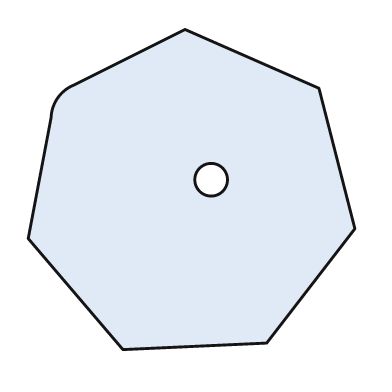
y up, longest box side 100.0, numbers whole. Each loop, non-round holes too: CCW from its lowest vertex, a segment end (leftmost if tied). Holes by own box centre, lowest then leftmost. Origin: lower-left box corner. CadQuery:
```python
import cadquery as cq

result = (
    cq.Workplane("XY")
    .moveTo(29.0, 0.0)
    .lineTo(73.0, 2.0)
    .lineTo(100.0, 37.0)
    .lineTo(89.0, 80.0)
    .lineTo(48.0, 98.0)
    .lineTo(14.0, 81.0)
    .threePointArc((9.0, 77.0), (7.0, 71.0))
    .lineTo(0.0, 34.0)
    .close()
    .moveTo(56.0, 52.0)
    .circle(5.0)
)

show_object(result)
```